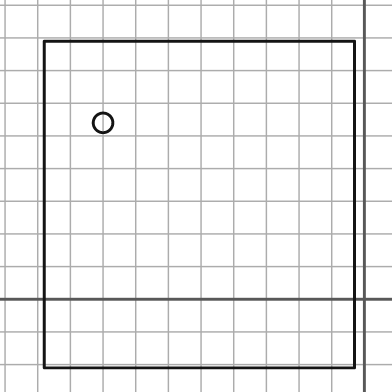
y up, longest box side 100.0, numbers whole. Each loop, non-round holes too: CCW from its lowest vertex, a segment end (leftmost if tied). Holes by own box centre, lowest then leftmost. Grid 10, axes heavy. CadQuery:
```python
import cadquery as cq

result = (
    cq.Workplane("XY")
    .moveTo(-98.0, -21.0)
    .lineTo(-3.0, -21.0)
    .lineTo(-3.0, 79.0)
    .lineTo(-98.0, 79.0)
    .close()
    .moveTo(-80.0, 54.0)
    .circle(3.0)
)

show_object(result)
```